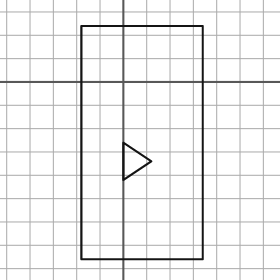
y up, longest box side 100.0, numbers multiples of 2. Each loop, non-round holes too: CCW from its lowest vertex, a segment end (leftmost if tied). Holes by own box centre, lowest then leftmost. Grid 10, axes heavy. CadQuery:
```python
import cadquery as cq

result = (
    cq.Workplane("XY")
    .moveTo(-18.0, -76.0)
    .lineTo(34.0, -76.0)
    .lineTo(34.0, 24.0)
    .lineTo(-18.0, 24.0)
    .close()
    .moveTo(0.0, -42.0)
    .lineTo(12.0, -34.0)
    .lineTo(0.0, -26.0)
    .close()
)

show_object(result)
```